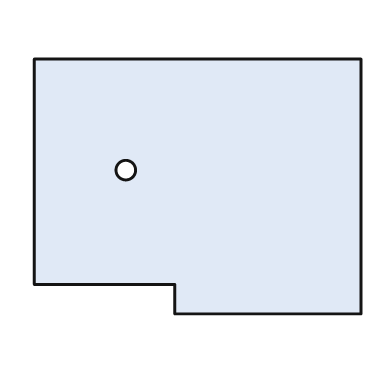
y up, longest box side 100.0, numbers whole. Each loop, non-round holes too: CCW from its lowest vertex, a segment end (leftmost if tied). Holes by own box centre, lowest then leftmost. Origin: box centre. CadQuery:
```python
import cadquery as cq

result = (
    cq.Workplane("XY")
    .moveTo(-7.0, -39.0)
    .lineTo(50.0, -39.0)
    .lineTo(50.0, 39.0)
    .lineTo(-50.0, 39.0)
    .lineTo(-50.0, -30.0)
    .lineTo(-7.0, -30.0)
    .close()
    .moveTo(-22.0, 5.0)
    .circle(3.0)
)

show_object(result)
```